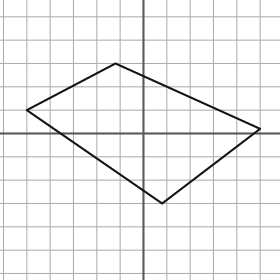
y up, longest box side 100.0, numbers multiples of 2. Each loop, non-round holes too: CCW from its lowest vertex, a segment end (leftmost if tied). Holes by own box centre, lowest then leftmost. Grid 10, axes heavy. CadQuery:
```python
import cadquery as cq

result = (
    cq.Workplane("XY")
    .moveTo(8.0, -30.0)
    .lineTo(50.0, 2.0)
    .lineTo(-12.0, 30.0)
    .lineTo(-50.0, 10.0)
    .close()
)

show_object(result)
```